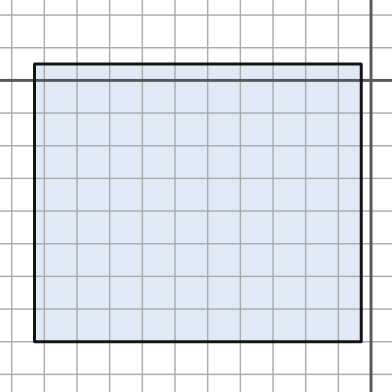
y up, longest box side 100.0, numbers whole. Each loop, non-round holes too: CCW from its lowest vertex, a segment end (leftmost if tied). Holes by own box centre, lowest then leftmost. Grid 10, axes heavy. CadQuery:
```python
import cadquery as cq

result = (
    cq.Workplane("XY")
    .moveTo(-103.0, -80.0)
    .lineTo(-3.0, -80.0)
    .lineTo(-3.0, 5.0)
    .lineTo(-103.0, 5.0)
    .close()
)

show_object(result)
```